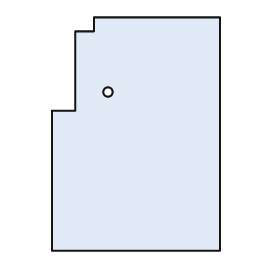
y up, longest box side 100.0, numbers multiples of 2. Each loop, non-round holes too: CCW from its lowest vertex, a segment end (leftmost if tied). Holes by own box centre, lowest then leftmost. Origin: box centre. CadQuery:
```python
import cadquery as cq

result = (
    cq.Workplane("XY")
    .moveTo(-36.0, -50.0)
    .lineTo(36.0, -50.0)
    .lineTo(36.0, 50.0)
    .lineTo(-18.0, 50.0)
    .lineTo(-18.0, 44.0)
    .lineTo(-26.0, 44.0)
    .lineTo(-26.0, 10.0)
    .lineTo(-36.0, 10.0)
    .close()
    .moveTo(-12.0, 18.0)
    .circle(2.0)
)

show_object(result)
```